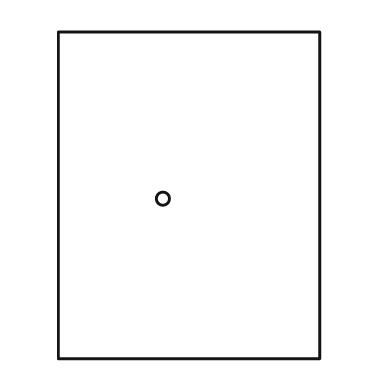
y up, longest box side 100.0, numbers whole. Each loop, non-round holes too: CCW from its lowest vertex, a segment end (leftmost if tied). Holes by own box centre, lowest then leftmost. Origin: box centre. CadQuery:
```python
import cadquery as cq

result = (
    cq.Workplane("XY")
    .moveTo(-40.0, -50.0)
    .lineTo(40.0, -50.0)
    .lineTo(40.0, 50.0)
    .lineTo(-40.0, 50.0)
    .close()
    .moveTo(-8.0, -1.0)
    .circle(2.0)
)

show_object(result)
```